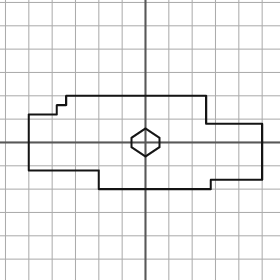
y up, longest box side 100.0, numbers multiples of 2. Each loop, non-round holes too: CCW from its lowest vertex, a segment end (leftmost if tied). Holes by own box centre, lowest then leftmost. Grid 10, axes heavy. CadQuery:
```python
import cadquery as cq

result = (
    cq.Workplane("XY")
    .moveTo(-20.0, -20.0)
    .lineTo(28.0, -20.0)
    .lineTo(28.0, -16.0)
    .lineTo(50.0, -16.0)
    .lineTo(50.0, 8.0)
    .lineTo(26.0, 8.0)
    .lineTo(26.0, 20.0)
    .lineTo(-34.0, 20.0)
    .lineTo(-34.0, 16.0)
    .lineTo(-38.0, 16.0)
    .lineTo(-38.0, 12.0)
    .lineTo(-50.0, 12.0)
    .lineTo(-50.0, -12.0)
    .lineTo(-20.0, -12.0)
    .close()
    .moveTo(0.0, -6.0)
    .lineTo(6.0, -2.0)
    .lineTo(6.0, 2.0)
    .lineTo(0.0, 6.0)
    .lineTo(-6.0, 2.0)
    .lineTo(-6.0, -2.0)
    .close()
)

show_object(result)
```